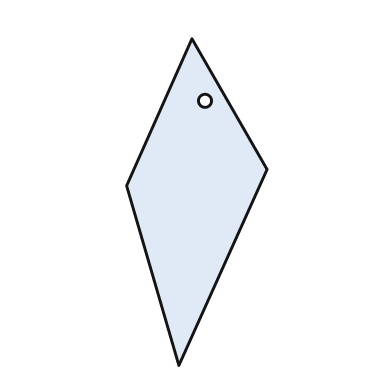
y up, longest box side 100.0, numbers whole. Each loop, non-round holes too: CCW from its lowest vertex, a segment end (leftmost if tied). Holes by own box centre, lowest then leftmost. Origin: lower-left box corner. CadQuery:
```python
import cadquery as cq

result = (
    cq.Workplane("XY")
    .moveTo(16.0, 0.0)
    .lineTo(43.0, 60.0)
    .lineTo(20.0, 100.0)
    .lineTo(0.0, 55.0)
    .close()
    .moveTo(24.0, 81.0)
    .circle(2.0)
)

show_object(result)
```